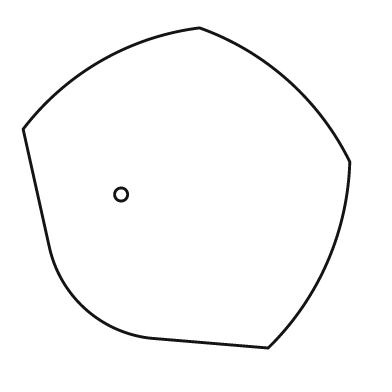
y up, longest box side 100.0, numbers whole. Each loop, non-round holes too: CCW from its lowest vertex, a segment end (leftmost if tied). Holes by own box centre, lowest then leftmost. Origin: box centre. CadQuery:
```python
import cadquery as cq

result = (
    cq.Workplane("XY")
    .moveTo(25.0, -49.0)
    .threePointArc((43.0, -23.0), (50.0, 8.0))
    .threePointArc((31.0, 33.0), (4.0, 49.0))
    .threePointArc((-26.0, 39.0), (-50.0, 18.0))
    .lineTo(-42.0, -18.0)
    .threePointArc((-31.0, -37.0), (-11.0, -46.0))
    .close()
    .moveTo(-20.0, -2.0)
    .circle(2.0)
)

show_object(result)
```